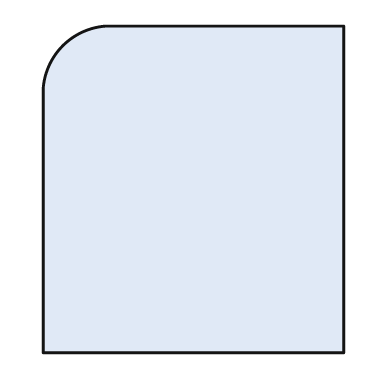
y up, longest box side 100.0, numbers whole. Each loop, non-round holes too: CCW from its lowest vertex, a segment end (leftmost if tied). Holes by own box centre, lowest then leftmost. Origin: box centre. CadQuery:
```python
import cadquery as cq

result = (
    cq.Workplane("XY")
    .moveTo(-46.0, -50.0)
    .lineTo(46.0, -50.0)
    .lineTo(46.0, 50.0)
    .lineTo(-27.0, 50.0)
    .threePointArc((-40.0, 44.0), (-46.0, 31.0))
    .close()
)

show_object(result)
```